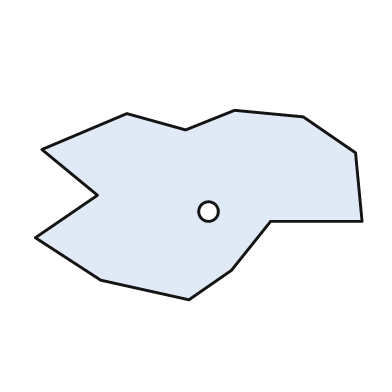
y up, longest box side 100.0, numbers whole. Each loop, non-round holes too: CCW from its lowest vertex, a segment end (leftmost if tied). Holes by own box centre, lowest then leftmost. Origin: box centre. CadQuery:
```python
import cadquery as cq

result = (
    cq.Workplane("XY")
    .moveTo(-3.0, -29.0)
    .lineTo(10.0, -20.0)
    .lineTo(22.0, -5.0)
    .lineTo(50.0, -5.0)
    .lineTo(48.0, 16.0)
    .lineTo(32.0, 27.0)
    .lineTo(11.0, 29.0)
    .lineTo(-4.0, 23.0)
    .lineTo(-22.0, 28.0)
    .lineTo(-48.0, 17.0)
    .lineTo(-31.0, 3.0)
    .lineTo(-50.0, -10.0)
    .lineTo(-30.0, -23.0)
    .close()
    .moveTo(3.0, -2.0)
    .circle(3.0)
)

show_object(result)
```